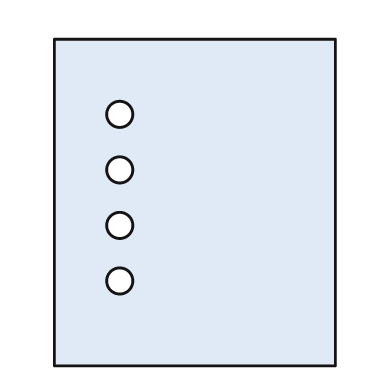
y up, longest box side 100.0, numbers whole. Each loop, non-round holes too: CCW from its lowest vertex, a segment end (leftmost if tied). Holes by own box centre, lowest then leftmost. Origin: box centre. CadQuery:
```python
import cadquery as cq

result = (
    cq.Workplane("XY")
    .moveTo(-43.0, -50.0)
    .lineTo(43.0, -50.0)
    .lineTo(43.0, 50.0)
    .lineTo(-43.0, 50.0)
    .close()
    .moveTo(-23.0, -24.0)
    .circle(4.0)
    .moveTo(-23.0, -7.0)
    .circle(4.0)
    .moveTo(-23.0, 10.0)
    .circle(4.0)
    .moveTo(-23.0, 27.0)
    .circle(4.0)
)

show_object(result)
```